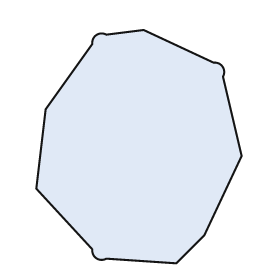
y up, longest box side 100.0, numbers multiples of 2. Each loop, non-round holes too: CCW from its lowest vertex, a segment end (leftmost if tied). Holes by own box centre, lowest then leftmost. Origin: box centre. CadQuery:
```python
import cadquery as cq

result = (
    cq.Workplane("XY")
    .moveTo(16.0, -50.0)
    .lineTo(28.0, -38.0)
    .lineTo(44.0, -4.0)
    .lineTo(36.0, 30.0)
    .threePointArc((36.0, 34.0), (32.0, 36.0))
    .lineTo(2.0, 50.0)
    .lineTo(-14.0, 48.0)
    .threePointArc((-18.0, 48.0), (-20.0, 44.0))
    .lineTo(-40.0, 16.0)
    .lineTo(-44.0, -18.0)
    .lineTo(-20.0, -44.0)
    .threePointArc((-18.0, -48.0), (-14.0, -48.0))
    .close()
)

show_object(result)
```